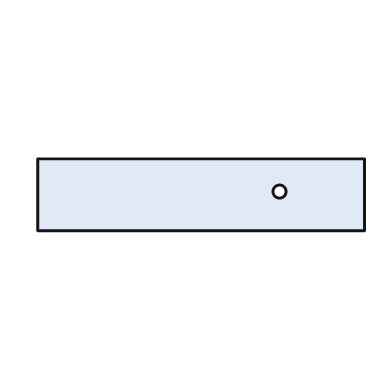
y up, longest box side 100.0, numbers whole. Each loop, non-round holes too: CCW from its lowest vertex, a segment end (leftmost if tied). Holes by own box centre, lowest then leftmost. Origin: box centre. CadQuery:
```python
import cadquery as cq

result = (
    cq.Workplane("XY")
    .moveTo(-50.0, -11.0)
    .lineTo(50.0, -11.0)
    .lineTo(50.0, 11.0)
    .lineTo(-50.0, 11.0)
    .close()
    .moveTo(24.0, 1.0)
    .circle(2.0)
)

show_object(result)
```